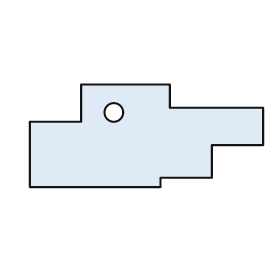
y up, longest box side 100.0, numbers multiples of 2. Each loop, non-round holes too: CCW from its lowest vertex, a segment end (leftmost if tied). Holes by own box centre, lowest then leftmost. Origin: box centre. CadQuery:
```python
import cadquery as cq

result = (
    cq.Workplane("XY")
    .moveTo(-50.0, -22.0)
    .lineTo(6.0, -22.0)
    .lineTo(6.0, -18.0)
    .lineTo(28.0, -18.0)
    .lineTo(28.0, -4.0)
    .lineTo(50.0, -4.0)
    .lineTo(50.0, 12.0)
    .lineTo(10.0, 12.0)
    .lineTo(10.0, 22.0)
    .lineTo(-28.0, 22.0)
    .lineTo(-28.0, 6.0)
    .lineTo(-50.0, 6.0)
    .close()
    .moveTo(-14.0, 10.0)
    .circle(4.0)
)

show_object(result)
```